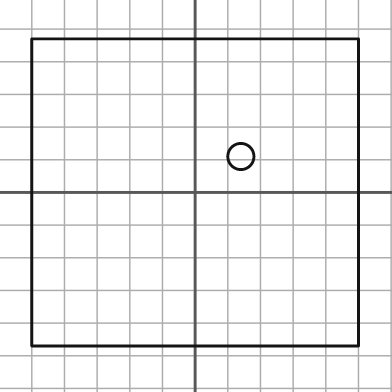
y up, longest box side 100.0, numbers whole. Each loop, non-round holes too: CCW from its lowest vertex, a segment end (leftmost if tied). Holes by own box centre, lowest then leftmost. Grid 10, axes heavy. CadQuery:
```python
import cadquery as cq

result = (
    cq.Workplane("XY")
    .moveTo(-50.0, -47.0)
    .lineTo(50.0, -47.0)
    .lineTo(50.0, 47.0)
    .lineTo(-50.0, 47.0)
    .close()
    .moveTo(14.0, 11.0)
    .circle(4.0)
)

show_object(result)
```